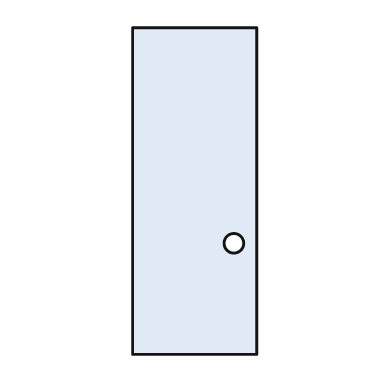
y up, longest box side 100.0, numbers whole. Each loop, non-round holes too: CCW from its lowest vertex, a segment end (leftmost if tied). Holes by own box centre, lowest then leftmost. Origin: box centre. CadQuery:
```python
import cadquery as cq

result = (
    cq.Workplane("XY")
    .moveTo(-19.0, -50.0)
    .lineTo(19.0, -50.0)
    .lineTo(19.0, 50.0)
    .lineTo(-19.0, 50.0)
    .close()
    .moveTo(12.0, -16.0)
    .circle(3.0)
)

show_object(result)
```